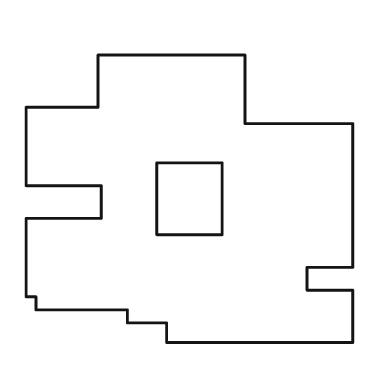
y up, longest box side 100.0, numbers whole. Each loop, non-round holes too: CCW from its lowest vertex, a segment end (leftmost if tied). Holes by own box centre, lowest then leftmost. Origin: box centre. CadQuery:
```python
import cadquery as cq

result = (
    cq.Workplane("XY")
    .moveTo(-7.0, -44.0)
    .lineTo(50.0, -44.0)
    .lineTo(50.0, -28.0)
    .lineTo(36.0, -28.0)
    .lineTo(36.0, -21.0)
    .lineTo(50.0, -21.0)
    .lineTo(50.0, 23.0)
    .lineTo(17.0, 23.0)
    .lineTo(17.0, 44.0)
    .lineTo(-28.0, 44.0)
    .lineTo(-28.0, 28.0)
    .lineTo(-50.0, 28.0)
    .lineTo(-50.0, 4.0)
    .lineTo(-27.0, 4.0)
    .lineTo(-27.0, -6.0)
    .lineTo(-50.0, -6.0)
    .lineTo(-50.0, -30.0)
    .lineTo(-47.0, -30.0)
    .lineTo(-47.0, -34.0)
    .lineTo(-19.0, -34.0)
    .lineTo(-19.0, -38.0)
    .lineTo(-7.0, -38.0)
    .close()
    .moveTo(-10.0, -11.0)
    .lineTo(10.0, -11.0)
    .lineTo(10.0, 11.0)
    .lineTo(-10.0, 11.0)
    .close()
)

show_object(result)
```